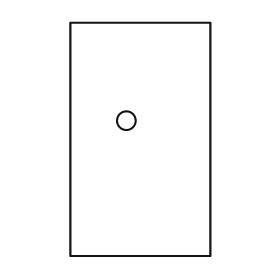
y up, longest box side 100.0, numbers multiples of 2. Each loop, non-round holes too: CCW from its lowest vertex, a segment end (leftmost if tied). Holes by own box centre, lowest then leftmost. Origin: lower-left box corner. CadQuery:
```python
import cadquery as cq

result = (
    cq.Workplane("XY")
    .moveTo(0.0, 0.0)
    .lineTo(60.0, 0.0)
    .lineTo(60.0, 100.0)
    .lineTo(0.0, 100.0)
    .close()
    .moveTo(24.0, 58.0)
    .circle(4.0)
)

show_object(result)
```